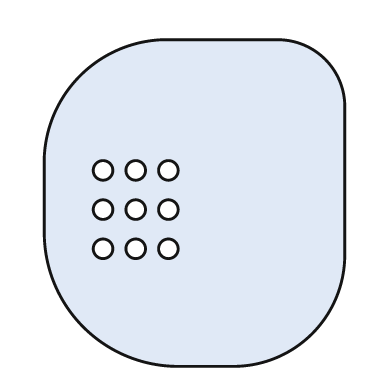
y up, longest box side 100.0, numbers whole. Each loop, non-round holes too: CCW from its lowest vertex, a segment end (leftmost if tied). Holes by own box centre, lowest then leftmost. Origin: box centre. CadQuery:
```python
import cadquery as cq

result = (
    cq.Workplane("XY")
    .moveTo(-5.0, -50.0)
    .lineTo(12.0, -50.0)
    .threePointArc((36.0, -40.0), (46.0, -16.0))
    .lineTo(46.0, 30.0)
    .threePointArc((40.0, 44.0), (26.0, 50.0))
    .lineTo(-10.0, 50.0)
    .threePointArc((-35.0, 39.0), (-46.0, 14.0))
    .lineTo(-46.0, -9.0)
    .threePointArc((-34.0, -38.0), (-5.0, -50.0))
    .close()
    .moveTo(-28.0, -14.0)
    .circle(3.0)
    .moveTo(-18.0, -14.0)
    .circle(3.0)
    .moveTo(-8.0, -14.0)
    .circle(3.0)
    .moveTo(-28.0, -2.0)
    .circle(3.0)
    .moveTo(-18.0, -2.0)
    .circle(3.0)
    .moveTo(-8.0, -2.0)
    .circle(3.0)
    .moveTo(-28.0, 10.0)
    .circle(3.0)
    .moveTo(-18.0, 10.0)
    .circle(3.0)
    .moveTo(-8.0, 10.0)
    .circle(3.0)
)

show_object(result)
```